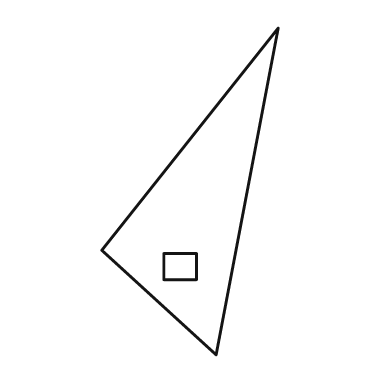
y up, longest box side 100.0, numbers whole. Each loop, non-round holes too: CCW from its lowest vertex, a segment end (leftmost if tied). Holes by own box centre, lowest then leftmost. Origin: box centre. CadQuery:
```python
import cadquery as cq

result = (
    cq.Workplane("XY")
    .moveTo(8.0, -50.0)
    .lineTo(27.0, 50.0)
    .lineTo(-27.0, -18.0)
    .close()
    .moveTo(-8.0, -27.0)
    .lineTo(2.0, -27.0)
    .lineTo(2.0, -19.0)
    .lineTo(-8.0, -19.0)
    .close()
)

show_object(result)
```